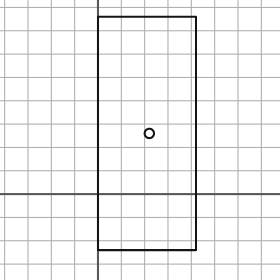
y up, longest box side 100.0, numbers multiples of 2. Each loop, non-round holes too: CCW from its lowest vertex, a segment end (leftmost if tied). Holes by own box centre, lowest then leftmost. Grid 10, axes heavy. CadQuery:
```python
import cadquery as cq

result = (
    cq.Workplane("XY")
    .moveTo(0.0, -24.0)
    .lineTo(42.0, -24.0)
    .lineTo(42.0, 76.0)
    .lineTo(0.0, 76.0)
    .close()
    .moveTo(22.0, 26.0)
    .circle(2.0)
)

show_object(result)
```